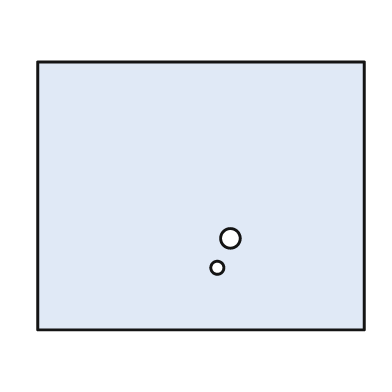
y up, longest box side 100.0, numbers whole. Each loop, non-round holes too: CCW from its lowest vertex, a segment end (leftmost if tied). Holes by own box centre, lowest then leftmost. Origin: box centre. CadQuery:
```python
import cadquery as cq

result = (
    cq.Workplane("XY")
    .moveTo(-50.0, -41.0)
    .lineTo(50.0, -41.0)
    .lineTo(50.0, 41.0)
    .lineTo(-50.0, 41.0)
    .close()
    .moveTo(5.0, -22.0)
    .circle(2.0)
    .moveTo(9.0, -13.0)
    .circle(3.0)
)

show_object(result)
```